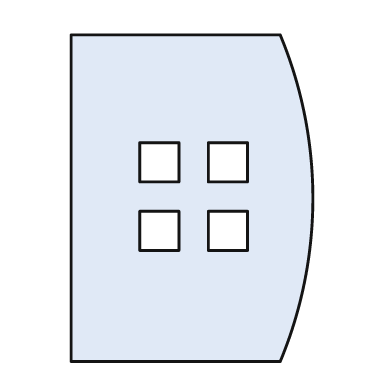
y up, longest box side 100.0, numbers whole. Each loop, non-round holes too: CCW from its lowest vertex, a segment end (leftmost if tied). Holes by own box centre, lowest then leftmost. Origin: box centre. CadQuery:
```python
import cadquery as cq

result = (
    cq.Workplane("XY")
    .moveTo(-37.0, -50.0)
    .lineTo(27.0, -50.0)
    .threePointArc((37.0, 0.0), (27.0, 50.0))
    .lineTo(-37.0, 50.0)
    .close()
    .moveTo(-16.0, -16.0)
    .lineTo(-4.0, -16.0)
    .lineTo(-4.0, -4.0)
    .lineTo(-16.0, -4.0)
    .close()
    .moveTo(5.0, -16.0)
    .lineTo(17.0, -16.0)
    .lineTo(17.0, -4.0)
    .lineTo(5.0, -4.0)
    .close()
    .moveTo(-16.0, 5.0)
    .lineTo(-4.0, 5.0)
    .lineTo(-4.0, 17.0)
    .lineTo(-16.0, 17.0)
    .close()
    .moveTo(5.0, 5.0)
    .lineTo(17.0, 5.0)
    .lineTo(17.0, 17.0)
    .lineTo(5.0, 17.0)
    .close()
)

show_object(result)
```